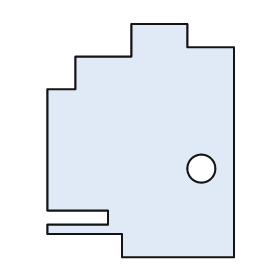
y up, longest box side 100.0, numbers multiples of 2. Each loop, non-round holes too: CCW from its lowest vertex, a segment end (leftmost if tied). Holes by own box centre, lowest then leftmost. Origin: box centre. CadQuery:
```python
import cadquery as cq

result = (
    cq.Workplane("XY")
    .moveTo(-8.0, -50.0)
    .lineTo(40.0, -50.0)
    .lineTo(40.0, 40.0)
    .lineTo(20.0, 40.0)
    .lineTo(20.0, 50.0)
    .lineTo(-4.0, 50.0)
    .lineTo(-4.0, 36.0)
    .lineTo(-28.0, 36.0)
    .lineTo(-28.0, 22.0)
    .lineTo(-40.0, 22.0)
    .lineTo(-40.0, -30.0)
    .lineTo(-14.0, -30.0)
    .lineTo(-14.0, -36.0)
    .lineTo(-40.0, -36.0)
    .lineTo(-40.0, -40.0)
    .lineTo(-8.0, -40.0)
    .close()
    .moveTo(26.0, -12.0)
    .circle(6.0)
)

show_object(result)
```